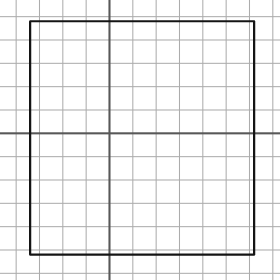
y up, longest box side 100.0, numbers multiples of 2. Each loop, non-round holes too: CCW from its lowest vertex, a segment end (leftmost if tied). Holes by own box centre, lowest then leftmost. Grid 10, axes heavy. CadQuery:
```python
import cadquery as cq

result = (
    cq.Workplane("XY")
    .moveTo(-34.0, -52.0)
    .lineTo(62.0, -52.0)
    .lineTo(62.0, 48.0)
    .lineTo(-34.0, 48.0)
    .close()
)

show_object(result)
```